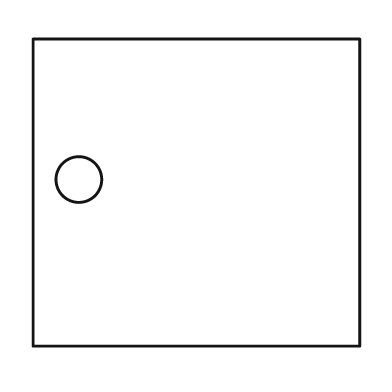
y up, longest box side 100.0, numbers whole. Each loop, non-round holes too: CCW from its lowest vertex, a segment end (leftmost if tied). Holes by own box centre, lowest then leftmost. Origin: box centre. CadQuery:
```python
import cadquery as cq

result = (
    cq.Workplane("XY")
    .moveTo(-50.0, -47.0)
    .lineTo(50.0, -47.0)
    .lineTo(50.0, 47.0)
    .lineTo(-50.0, 47.0)
    .close()
    .moveTo(-36.0, 4.0)
    .circle(7.0)
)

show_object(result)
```